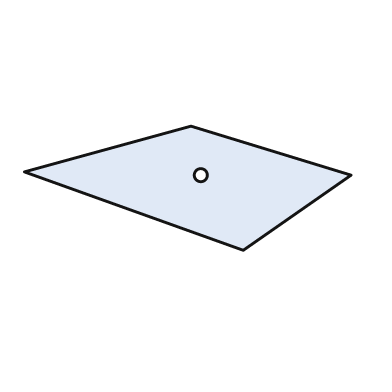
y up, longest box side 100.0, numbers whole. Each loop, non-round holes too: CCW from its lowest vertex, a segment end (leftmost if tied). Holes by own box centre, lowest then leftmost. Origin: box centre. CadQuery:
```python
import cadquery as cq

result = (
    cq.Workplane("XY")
    .moveTo(17.0, -19.0)
    .lineTo(50.0, 4.0)
    .lineTo(1.0, 19.0)
    .lineTo(-50.0, 5.0)
    .close()
    .moveTo(4.0, 4.0)
    .circle(2.0)
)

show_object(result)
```